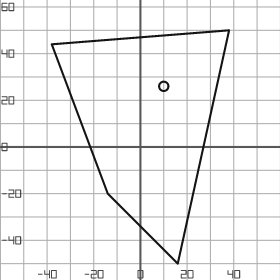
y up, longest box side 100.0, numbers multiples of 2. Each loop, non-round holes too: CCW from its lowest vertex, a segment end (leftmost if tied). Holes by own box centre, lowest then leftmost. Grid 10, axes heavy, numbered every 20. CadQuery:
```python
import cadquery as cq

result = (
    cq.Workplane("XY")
    .moveTo(16.0, -50.0)
    .lineTo(38.0, 50.0)
    .lineTo(-38.0, 44.0)
    .lineTo(-14.0, -20.0)
    .close()
    .moveTo(10.0, 26.0)
    .circle(2.0)
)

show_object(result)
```